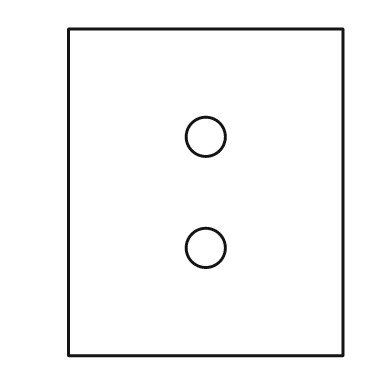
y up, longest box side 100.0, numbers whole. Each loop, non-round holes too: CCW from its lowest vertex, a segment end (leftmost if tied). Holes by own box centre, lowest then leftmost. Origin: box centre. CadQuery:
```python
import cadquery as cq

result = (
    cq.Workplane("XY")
    .moveTo(-42.0, -50.0)
    .lineTo(42.0, -50.0)
    .lineTo(42.0, 50.0)
    .lineTo(-42.0, 50.0)
    .close()
    .moveTo(0.0, -17.0)
    .circle(6.0)
    .moveTo(0.0, 17.0)
    .circle(6.0)
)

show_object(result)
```